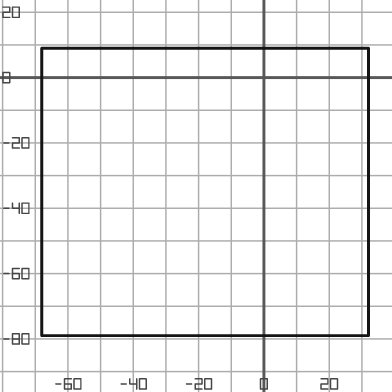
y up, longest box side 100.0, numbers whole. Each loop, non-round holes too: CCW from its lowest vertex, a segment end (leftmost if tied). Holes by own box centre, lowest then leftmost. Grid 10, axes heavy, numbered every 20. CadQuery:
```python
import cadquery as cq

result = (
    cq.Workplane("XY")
    .moveTo(-68.0, -79.0)
    .lineTo(32.0, -79.0)
    .lineTo(32.0, 9.0)
    .lineTo(-68.0, 9.0)
    .close()
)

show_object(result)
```